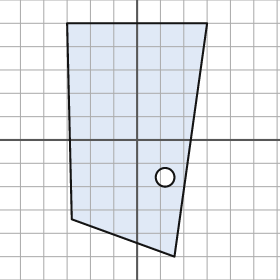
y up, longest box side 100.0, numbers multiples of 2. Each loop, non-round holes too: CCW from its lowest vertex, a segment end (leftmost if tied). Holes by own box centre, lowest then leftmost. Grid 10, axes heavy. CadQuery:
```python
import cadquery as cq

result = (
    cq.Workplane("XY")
    .moveTo(16.0, -50.0)
    .lineTo(30.0, 50.0)
    .lineTo(-30.0, 50.0)
    .lineTo(-28.0, -34.0)
    .close()
    .moveTo(12.0, -16.0)
    .circle(4.0)
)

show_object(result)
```